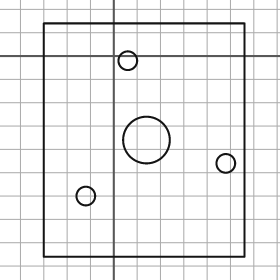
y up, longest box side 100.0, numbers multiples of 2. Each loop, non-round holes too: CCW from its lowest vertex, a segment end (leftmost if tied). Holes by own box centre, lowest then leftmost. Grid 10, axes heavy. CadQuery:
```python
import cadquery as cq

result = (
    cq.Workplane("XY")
    .moveTo(-30.0, -86.0)
    .lineTo(56.0, -86.0)
    .lineTo(56.0, 14.0)
    .lineTo(-30.0, 14.0)
    .close()
    .moveTo(-12.0, -60.0)
    .circle(4.0)
    .moveTo(48.0, -46.0)
    .circle(4.0)
    .moveTo(14.0, -36.0)
    .circle(10.0)
    .moveTo(6.0, -2.0)
    .circle(4.0)
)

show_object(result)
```